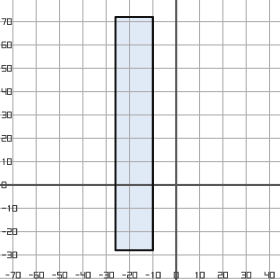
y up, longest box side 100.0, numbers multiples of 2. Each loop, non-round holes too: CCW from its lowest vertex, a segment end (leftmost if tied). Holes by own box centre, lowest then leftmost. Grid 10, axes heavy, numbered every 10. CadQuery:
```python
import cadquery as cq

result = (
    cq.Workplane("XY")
    .moveTo(-26.0, -28.0)
    .lineTo(-10.0, -28.0)
    .lineTo(-10.0, 72.0)
    .lineTo(-26.0, 72.0)
    .close()
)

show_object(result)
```